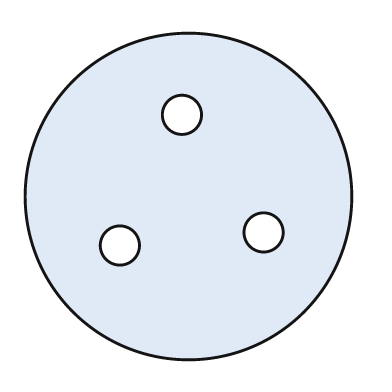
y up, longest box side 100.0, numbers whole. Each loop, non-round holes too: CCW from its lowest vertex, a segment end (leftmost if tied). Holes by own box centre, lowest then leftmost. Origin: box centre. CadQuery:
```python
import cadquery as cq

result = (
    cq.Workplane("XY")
    .moveTo(0.0, 0.0)
    .circle(50.0)
    .moveTo(-21.0, -15.0)
    .circle(6.0)
    .moveTo(23.0, -11.0)
    .circle(6.0)
    .moveTo(-2.0, 25.0)
    .circle(6.0)
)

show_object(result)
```